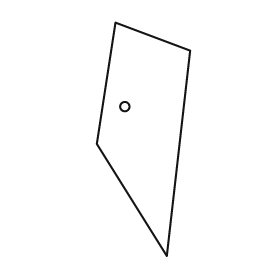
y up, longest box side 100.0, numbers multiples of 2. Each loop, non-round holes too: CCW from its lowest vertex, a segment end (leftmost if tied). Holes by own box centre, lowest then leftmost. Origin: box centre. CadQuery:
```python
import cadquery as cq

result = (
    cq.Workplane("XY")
    .moveTo(10.0, -50.0)
    .lineTo(20.0, 38.0)
    .lineTo(-12.0, 50.0)
    .lineTo(-20.0, -2.0)
    .close()
    .moveTo(-8.0, 14.0)
    .circle(2.0)
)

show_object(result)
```